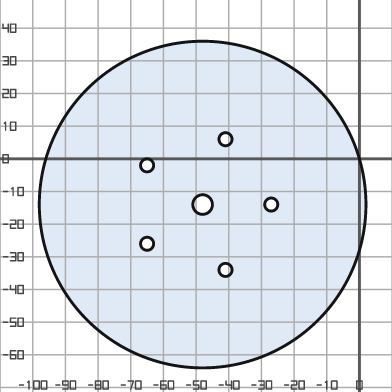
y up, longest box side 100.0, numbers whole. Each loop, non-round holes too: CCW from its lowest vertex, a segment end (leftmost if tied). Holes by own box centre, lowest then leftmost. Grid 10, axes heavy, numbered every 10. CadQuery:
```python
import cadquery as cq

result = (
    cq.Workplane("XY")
    .moveTo(-48.0, -14.0)
    .circle(50.0)
    .moveTo(-41.0, -34.0)
    .circle(2.0)
    .moveTo(-65.0, -26.0)
    .circle(2.0)
    .moveTo(-48.0, -14.0)
    .circle(3.0)
    .moveTo(-27.0, -14.0)
    .circle(2.0)
    .moveTo(-65.0, -2.0)
    .circle(2.0)
    .moveTo(-41.0, 6.0)
    .circle(2.0)
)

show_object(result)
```